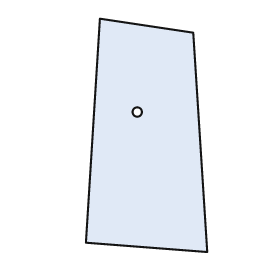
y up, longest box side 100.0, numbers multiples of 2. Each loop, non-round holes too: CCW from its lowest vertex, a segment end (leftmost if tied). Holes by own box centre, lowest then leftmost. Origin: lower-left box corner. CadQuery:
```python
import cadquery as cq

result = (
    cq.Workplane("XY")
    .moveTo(52.0, 0.0)
    .lineTo(46.0, 94.0)
    .lineTo(6.0, 100.0)
    .lineTo(0.0, 4.0)
    .close()
    .moveTo(22.0, 60.0)
    .circle(2.0)
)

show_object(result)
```